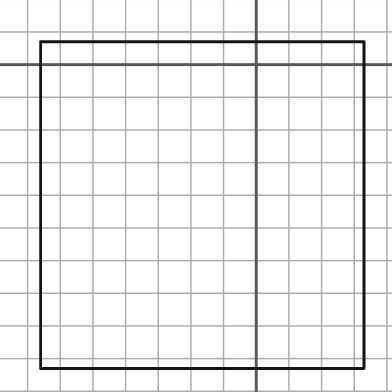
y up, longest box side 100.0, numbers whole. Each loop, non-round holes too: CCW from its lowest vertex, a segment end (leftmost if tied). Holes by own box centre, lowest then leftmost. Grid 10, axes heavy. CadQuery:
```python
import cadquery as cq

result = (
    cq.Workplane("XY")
    .moveTo(-66.0, -93.0)
    .lineTo(33.0, -93.0)
    .lineTo(33.0, 7.0)
    .lineTo(-66.0, 7.0)
    .close()
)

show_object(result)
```